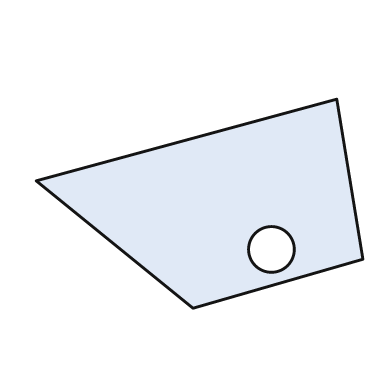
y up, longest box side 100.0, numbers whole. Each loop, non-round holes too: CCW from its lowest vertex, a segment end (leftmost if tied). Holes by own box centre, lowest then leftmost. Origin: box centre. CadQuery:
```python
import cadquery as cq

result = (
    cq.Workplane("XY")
    .moveTo(-2.0, -32.0)
    .lineTo(50.0, -17.0)
    .lineTo(42.0, 32.0)
    .lineTo(-50.0, 7.0)
    .close()
    .moveTo(22.0, -14.0)
    .circle(7.0)
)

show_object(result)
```